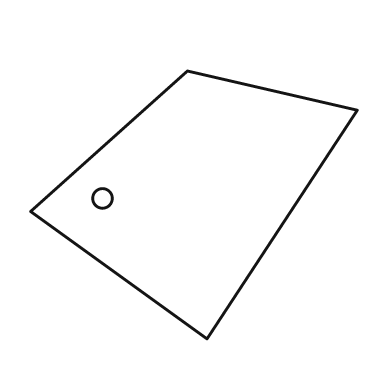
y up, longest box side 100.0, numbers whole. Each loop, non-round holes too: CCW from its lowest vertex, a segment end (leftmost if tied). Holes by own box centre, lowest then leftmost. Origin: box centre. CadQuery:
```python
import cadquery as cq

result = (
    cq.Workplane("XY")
    .moveTo(4.0, -41.0)
    .lineTo(50.0, 29.0)
    .lineTo(-2.0, 41.0)
    .lineTo(-50.0, -2.0)
    .close()
    .moveTo(-28.0, 2.0)
    .circle(3.0)
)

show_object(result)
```